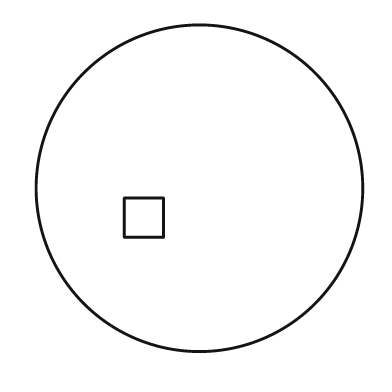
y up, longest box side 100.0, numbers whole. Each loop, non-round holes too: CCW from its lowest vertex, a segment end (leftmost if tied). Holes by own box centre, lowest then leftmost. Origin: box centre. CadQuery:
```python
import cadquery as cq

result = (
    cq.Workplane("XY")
    .moveTo(0.0, 0.0)
    .circle(50.0)
    .moveTo(-23.0, -15.0)
    .lineTo(-11.0, -15.0)
    .lineTo(-11.0, -3.0)
    .lineTo(-23.0, -3.0)
    .close()
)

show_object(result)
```